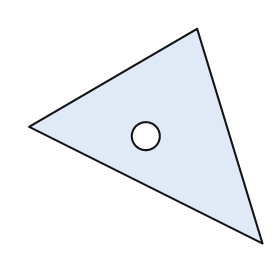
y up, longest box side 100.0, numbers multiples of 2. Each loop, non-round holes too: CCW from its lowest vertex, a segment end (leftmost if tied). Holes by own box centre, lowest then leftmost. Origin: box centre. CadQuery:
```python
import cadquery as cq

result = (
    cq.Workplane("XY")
    .moveTo(50.0, -46.0)
    .lineTo(22.0, 46.0)
    .lineTo(-50.0, 4.0)
    .close()
    .moveTo(0.0, 0.0)
    .circle(6.0)
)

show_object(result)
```